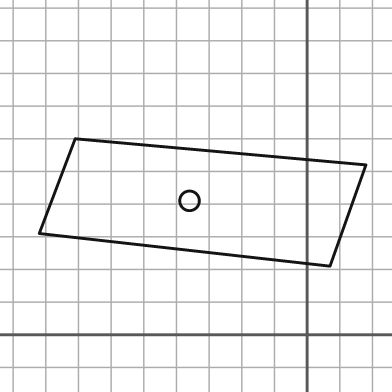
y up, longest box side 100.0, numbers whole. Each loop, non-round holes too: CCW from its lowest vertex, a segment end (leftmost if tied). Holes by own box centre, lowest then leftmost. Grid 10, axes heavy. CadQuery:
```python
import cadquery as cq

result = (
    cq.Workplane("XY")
    .moveTo(7.0, 21.0)
    .lineTo(18.0, 52.0)
    .lineTo(-71.0, 60.0)
    .lineTo(-82.0, 31.0)
    .close()
    .moveTo(-36.0, 41.0)
    .circle(3.0)
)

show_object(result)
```